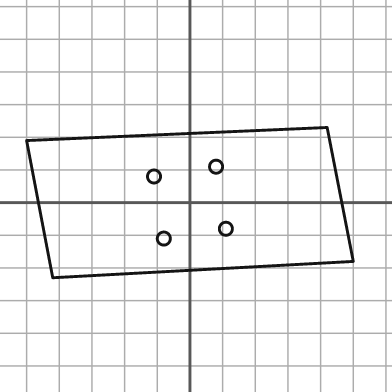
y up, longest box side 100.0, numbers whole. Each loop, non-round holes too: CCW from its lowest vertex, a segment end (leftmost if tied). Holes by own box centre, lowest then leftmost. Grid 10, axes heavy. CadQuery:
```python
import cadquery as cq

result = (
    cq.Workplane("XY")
    .moveTo(-42.0, -23.0)
    .lineTo(50.0, -18.0)
    .lineTo(42.0, 23.0)
    .lineTo(-50.0, 19.0)
    .close()
    .moveTo(-8.0, -11.0)
    .circle(2.0)
    .moveTo(11.0, -8.0)
    .circle(2.0)
    .moveTo(-11.0, 8.0)
    .circle(2.0)
    .moveTo(8.0, 11.0)
    .circle(2.0)
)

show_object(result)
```